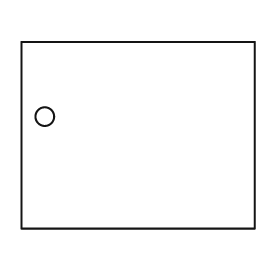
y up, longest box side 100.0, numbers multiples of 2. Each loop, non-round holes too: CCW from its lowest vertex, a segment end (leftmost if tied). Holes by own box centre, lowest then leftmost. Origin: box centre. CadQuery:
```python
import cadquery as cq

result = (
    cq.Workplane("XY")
    .moveTo(-50.0, -40.0)
    .lineTo(50.0, -40.0)
    .lineTo(50.0, 40.0)
    .lineTo(-50.0, 40.0)
    .close()
    .moveTo(-40.0, 8.0)
    .circle(4.0)
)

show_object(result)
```